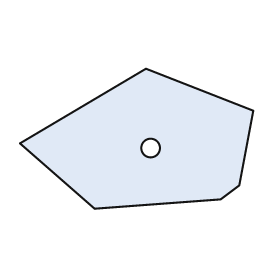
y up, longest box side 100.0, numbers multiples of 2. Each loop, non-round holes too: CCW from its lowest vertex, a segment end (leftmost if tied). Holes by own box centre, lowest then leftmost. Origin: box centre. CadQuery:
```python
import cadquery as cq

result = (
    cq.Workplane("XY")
    .moveTo(-18.0, -30.0)
    .lineTo(36.0, -26.0)
    .lineTo(44.0, -20.0)
    .lineTo(50.0, 12.0)
    .lineTo(4.0, 30.0)
    .lineTo(-50.0, -2.0)
    .close()
    .moveTo(6.0, -4.0)
    .circle(4.0)
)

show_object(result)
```